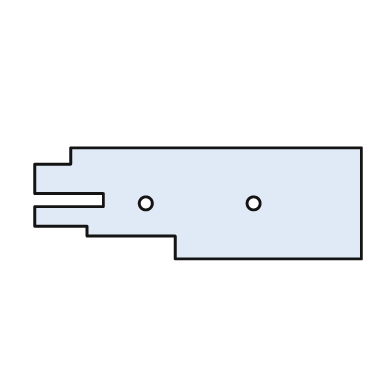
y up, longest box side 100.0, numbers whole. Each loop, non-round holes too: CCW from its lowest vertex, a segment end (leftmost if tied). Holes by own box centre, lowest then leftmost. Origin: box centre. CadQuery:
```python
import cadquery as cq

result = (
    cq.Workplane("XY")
    .moveTo(-7.0, -17.0)
    .lineTo(50.0, -17.0)
    .lineTo(50.0, 17.0)
    .lineTo(-39.0, 17.0)
    .lineTo(-39.0, 12.0)
    .lineTo(-50.0, 12.0)
    .lineTo(-50.0, 3.0)
    .lineTo(-29.0, 3.0)
    .lineTo(-29.0, -1.0)
    .lineTo(-50.0, -1.0)
    .lineTo(-50.0, -7.0)
    .lineTo(-34.0, -7.0)
    .lineTo(-34.0, -10.0)
    .lineTo(-7.0, -10.0)
    .close()
    .moveTo(-16.0, 0.0)
    .circle(2.0)
    .moveTo(17.0, 0.0)
    .circle(2.0)
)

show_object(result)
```